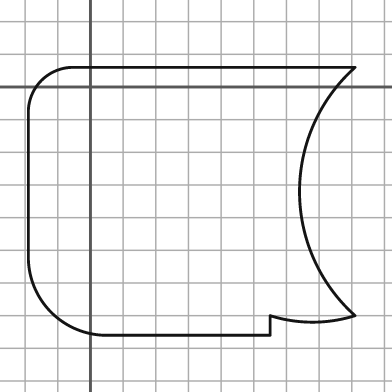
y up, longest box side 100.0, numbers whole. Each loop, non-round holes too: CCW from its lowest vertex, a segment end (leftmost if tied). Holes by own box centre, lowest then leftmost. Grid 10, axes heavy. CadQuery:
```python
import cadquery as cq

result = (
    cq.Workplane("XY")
    .moveTo(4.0, -76.0)
    .lineTo(55.0, -76.0)
    .lineTo(55.0, -70.0)
    .threePointArc((68.0, -72.0), (81.0, -70.0))
    .threePointArc((64.0, -32.0), (81.0, 6.0))
    .lineTo(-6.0, 6.0)
    .threePointArc((-15.0, 2.0), (-19.0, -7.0))
    .lineTo(-19.0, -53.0)
    .threePointArc((-12.0, -69.0), (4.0, -76.0))
    .close()
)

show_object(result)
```